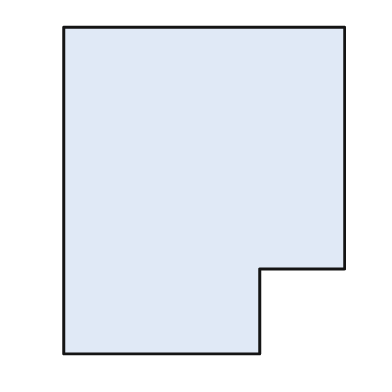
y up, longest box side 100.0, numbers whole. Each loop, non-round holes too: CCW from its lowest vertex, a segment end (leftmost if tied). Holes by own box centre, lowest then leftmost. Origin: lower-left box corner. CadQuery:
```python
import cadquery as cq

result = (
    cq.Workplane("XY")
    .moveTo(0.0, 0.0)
    .lineTo(60.0, 0.0)
    .lineTo(60.0, 26.0)
    .lineTo(86.0, 26.0)
    .lineTo(86.0, 100.0)
    .lineTo(0.0, 100.0)
    .close()
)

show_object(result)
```